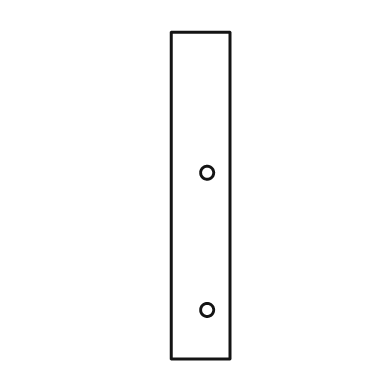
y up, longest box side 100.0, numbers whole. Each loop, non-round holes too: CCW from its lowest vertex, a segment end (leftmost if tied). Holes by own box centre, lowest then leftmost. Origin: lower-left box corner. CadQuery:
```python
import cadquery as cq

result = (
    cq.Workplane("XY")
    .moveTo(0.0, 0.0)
    .lineTo(18.0, 0.0)
    .lineTo(18.0, 100.0)
    .lineTo(0.0, 100.0)
    .close()
    .moveTo(11.0, 15.0)
    .circle(2.0)
    .moveTo(11.0, 57.0)
    .circle(2.0)
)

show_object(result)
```